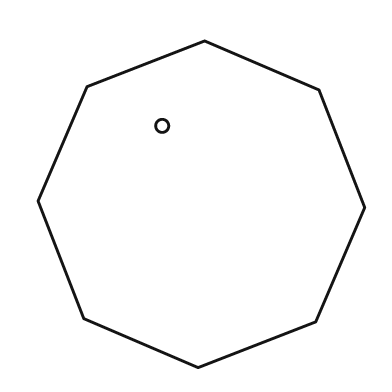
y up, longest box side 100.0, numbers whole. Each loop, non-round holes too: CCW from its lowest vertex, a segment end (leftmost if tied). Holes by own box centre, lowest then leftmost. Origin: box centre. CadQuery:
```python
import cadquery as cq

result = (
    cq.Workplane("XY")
    .moveTo(-1.0, -50.0)
    .lineTo(35.0, -36.0)
    .lineTo(50.0, -1.0)
    .lineTo(36.0, 35.0)
    .lineTo(1.0, 50.0)
    .lineTo(-35.0, 36.0)
    .lineTo(-50.0, 1.0)
    .lineTo(-36.0, -35.0)
    .close()
    .moveTo(-12.0, 24.0)
    .circle(2.0)
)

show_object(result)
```